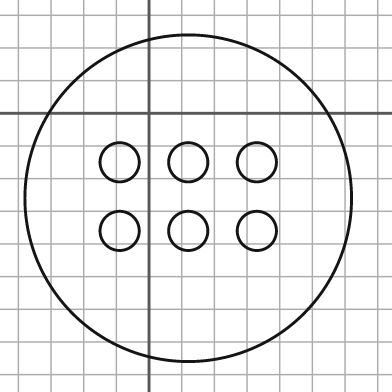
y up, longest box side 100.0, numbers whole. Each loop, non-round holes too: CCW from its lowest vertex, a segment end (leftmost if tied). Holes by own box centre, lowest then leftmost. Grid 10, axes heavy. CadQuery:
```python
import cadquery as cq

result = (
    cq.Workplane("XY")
    .moveTo(12.0, -26.0)
    .circle(50.0)
    .moveTo(-9.0, -36.0)
    .circle(6.0)
    .moveTo(12.0, -36.0)
    .circle(6.0)
    .moveTo(33.0, -36.0)
    .circle(6.0)
    .moveTo(-9.0, -15.0)
    .circle(6.0)
    .moveTo(12.0, -15.0)
    .circle(6.0)
    .moveTo(33.0, -15.0)
    .circle(6.0)
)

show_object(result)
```